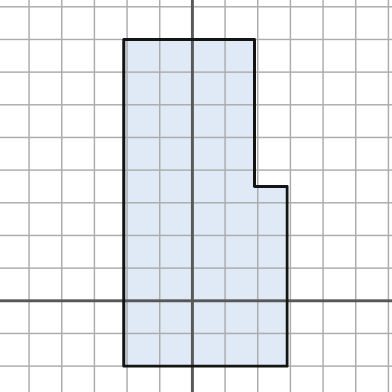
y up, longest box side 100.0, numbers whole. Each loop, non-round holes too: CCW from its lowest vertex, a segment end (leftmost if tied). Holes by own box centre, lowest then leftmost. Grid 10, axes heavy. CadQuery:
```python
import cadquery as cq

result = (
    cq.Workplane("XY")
    .moveTo(-21.0, -20.0)
    .lineTo(29.0, -20.0)
    .lineTo(29.0, 35.0)
    .lineTo(19.0, 35.0)
    .lineTo(19.0, 80.0)
    .lineTo(-21.0, 80.0)
    .close()
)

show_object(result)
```